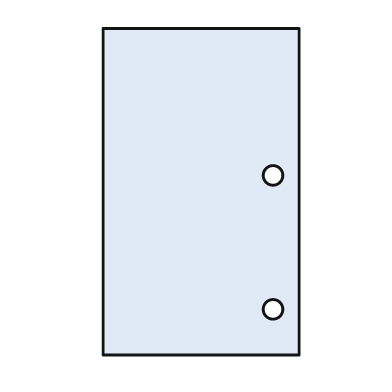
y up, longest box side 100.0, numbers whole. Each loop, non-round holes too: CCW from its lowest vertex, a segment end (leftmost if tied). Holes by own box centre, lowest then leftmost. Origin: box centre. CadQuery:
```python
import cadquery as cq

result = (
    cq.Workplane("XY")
    .moveTo(-30.0, -50.0)
    .lineTo(30.0, -50.0)
    .lineTo(30.0, 50.0)
    .lineTo(-30.0, 50.0)
    .close()
    .moveTo(22.0, -36.0)
    .circle(3.0)
    .moveTo(22.0, 5.0)
    .circle(3.0)
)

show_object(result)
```